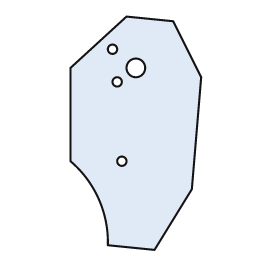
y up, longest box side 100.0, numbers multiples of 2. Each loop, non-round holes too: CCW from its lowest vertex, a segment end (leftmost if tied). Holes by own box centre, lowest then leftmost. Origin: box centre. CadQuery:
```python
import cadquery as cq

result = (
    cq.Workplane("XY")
    .moveTo(8.0, -50.0)
    .lineTo(24.0, -24.0)
    .lineTo(28.0, 24.0)
    .lineTo(16.0, 48.0)
    .lineTo(-4.0, 50.0)
    .lineTo(-28.0, 28.0)
    .lineTo(-28.0, -12.0)
    .threePointArc((-16.0, -28.0), (-12.0, -48.0))
    .close()
    .moveTo(-6.0, -12.0)
    .circle(2.0)
    .moveTo(-8.0, 22.0)
    .circle(2.0)
    .moveTo(0.0, 28.0)
    .circle(4.0)
    .moveTo(-10.0, 36.0)
    .circle(2.0)
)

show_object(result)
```